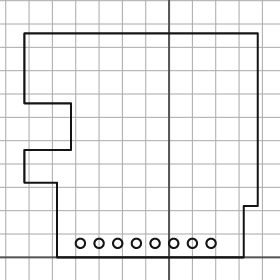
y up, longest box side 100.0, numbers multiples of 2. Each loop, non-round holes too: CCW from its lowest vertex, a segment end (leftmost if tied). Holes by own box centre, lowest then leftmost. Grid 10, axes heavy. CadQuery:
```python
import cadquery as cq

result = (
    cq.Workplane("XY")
    .moveTo(-48.0, 0.0)
    .lineTo(32.0, 0.0)
    .lineTo(32.0, 22.0)
    .lineTo(38.0, 22.0)
    .lineTo(38.0, 96.0)
    .lineTo(-62.0, 96.0)
    .lineTo(-62.0, 66.0)
    .lineTo(-42.0, 66.0)
    .lineTo(-42.0, 46.0)
    .lineTo(-62.0, 46.0)
    .lineTo(-62.0, 32.0)
    .lineTo(-48.0, 32.0)
    .close()
    .moveTo(-38.0, 6.0)
    .circle(2.0)
    .moveTo(-30.0, 6.0)
    .circle(2.0)
    .moveTo(-22.0, 6.0)
    .circle(2.0)
    .moveTo(-14.0, 6.0)
    .circle(2.0)
    .moveTo(-6.0, 6.0)
    .circle(2.0)
    .moveTo(2.0, 6.0)
    .circle(2.0)
    .moveTo(10.0, 6.0)
    .circle(2.0)
    .moveTo(18.0, 6.0)
    .circle(2.0)
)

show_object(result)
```